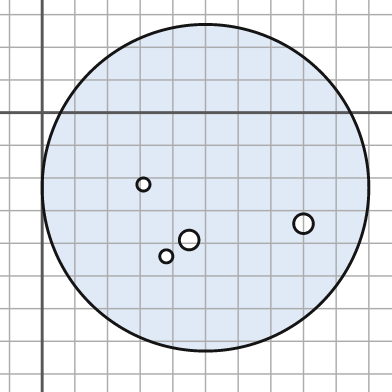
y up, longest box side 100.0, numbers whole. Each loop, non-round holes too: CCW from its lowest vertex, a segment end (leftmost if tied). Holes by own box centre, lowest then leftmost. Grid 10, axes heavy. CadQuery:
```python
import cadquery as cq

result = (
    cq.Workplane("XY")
    .moveTo(50.0, -23.0)
    .circle(50.0)
    .moveTo(38.0, -44.0)
    .circle(2.0)
    .moveTo(45.0, -39.0)
    .circle(3.0)
    .moveTo(80.0, -34.0)
    .circle(3.0)
    .moveTo(31.0, -22.0)
    .circle(2.0)
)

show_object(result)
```